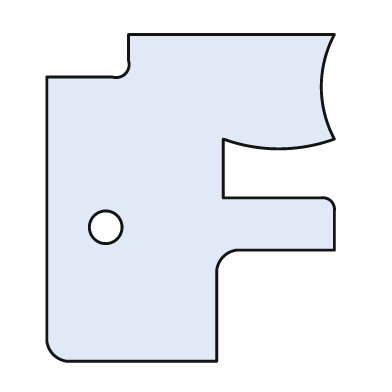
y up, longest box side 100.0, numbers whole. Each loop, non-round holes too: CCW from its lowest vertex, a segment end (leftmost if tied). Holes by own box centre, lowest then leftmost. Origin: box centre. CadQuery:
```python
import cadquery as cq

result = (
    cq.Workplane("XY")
    .moveTo(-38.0, -50.0)
    .lineTo(8.0, -50.0)
    .lineTo(8.0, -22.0)
    .threePointArc((10.0, -18.0), (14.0, -16.0))
    .lineTo(44.0, -16.0)
    .lineTo(44.0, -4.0)
    .threePointArc((43.0, -1.0), (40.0, 0.0))
    .lineTo(10.0, 0.0)
    .lineTo(10.0, 18.0)
    .threePointArc((27.0, 15.0), (44.0, 18.0))
    .threePointArc((40.0, 34.0), (44.0, 50.0))
    .lineTo(-19.0, 50.0)
    .lineTo(-19.0, 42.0)
    .threePointArc((-20.0, 38.0), (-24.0, 37.0))
    .lineTo(-44.0, 37.0)
    .lineTo(-44.0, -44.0)
    .threePointArc((-42.0, -48.0), (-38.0, -50.0))
    .close()
    .moveTo(-26.0, -9.0)
    .circle(5.0)
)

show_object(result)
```